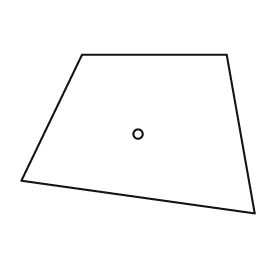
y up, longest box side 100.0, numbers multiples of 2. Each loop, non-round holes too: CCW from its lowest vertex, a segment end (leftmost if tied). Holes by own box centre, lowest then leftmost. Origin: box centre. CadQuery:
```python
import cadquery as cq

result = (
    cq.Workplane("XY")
    .moveTo(50.0, -34.0)
    .lineTo(38.0, 34.0)
    .lineTo(-24.0, 34.0)
    .lineTo(-50.0, -20.0)
    .close()
    .moveTo(0.0, 0.0)
    .circle(2.0)
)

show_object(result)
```